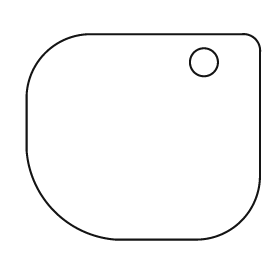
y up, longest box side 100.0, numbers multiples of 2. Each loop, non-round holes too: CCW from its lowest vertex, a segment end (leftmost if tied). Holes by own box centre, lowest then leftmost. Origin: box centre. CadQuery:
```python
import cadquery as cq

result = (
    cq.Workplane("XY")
    .moveTo(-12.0, -44.0)
    .lineTo(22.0, -44.0)
    .threePointArc((42.0, -36.0), (50.0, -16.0))
    .lineTo(50.0, 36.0)
    .threePointArc((48.0, 42.0), (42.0, 44.0))
    .lineTo(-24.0, 44.0)
    .threePointArc((-42.0, 36.0), (-50.0, 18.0))
    .lineTo(-50.0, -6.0)
    .threePointArc((-38.0, -32.0), (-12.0, -44.0))
    .close()
    .moveTo(26.0, 32.0)
    .circle(6.0)
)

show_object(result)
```